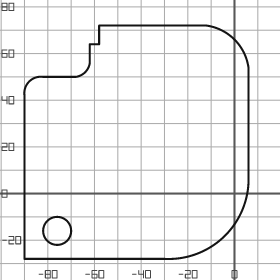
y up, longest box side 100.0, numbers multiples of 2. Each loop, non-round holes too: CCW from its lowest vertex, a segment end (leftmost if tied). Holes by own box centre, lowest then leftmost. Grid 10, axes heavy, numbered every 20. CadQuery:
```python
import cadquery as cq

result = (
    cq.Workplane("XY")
    .moveTo(-90.0, -28.0)
    .lineTo(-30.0, -28.0)
    .threePointArc((-4.0, -18.0), (6.0, 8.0))
    .lineTo(6.0, 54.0)
    .threePointArc((0.0, 66.0), (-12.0, 72.0))
    .lineTo(-58.0, 72.0)
    .lineTo(-58.0, 64.0)
    .lineTo(-62.0, 64.0)
    .lineTo(-62.0, 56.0)
    .threePointArc((-64.0, 52.0), (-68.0, 50.0))
    .lineTo(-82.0, 50.0)
    .threePointArc((-88.0, 48.0), (-90.0, 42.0))
    .close()
    .moveTo(-76.0, -16.0)
    .circle(6.0)
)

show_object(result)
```